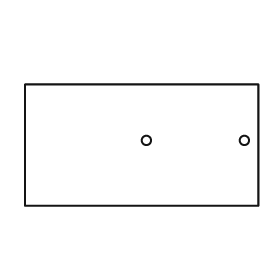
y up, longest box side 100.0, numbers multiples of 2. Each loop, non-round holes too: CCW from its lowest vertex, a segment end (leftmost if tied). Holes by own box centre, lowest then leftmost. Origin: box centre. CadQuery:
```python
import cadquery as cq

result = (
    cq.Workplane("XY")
    .moveTo(-50.0, -26.0)
    .lineTo(50.0, -26.0)
    .lineTo(50.0, 26.0)
    .lineTo(-50.0, 26.0)
    .close()
    .moveTo(2.0, 2.0)
    .circle(2.0)
    .moveTo(44.0, 2.0)
    .circle(2.0)
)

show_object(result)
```